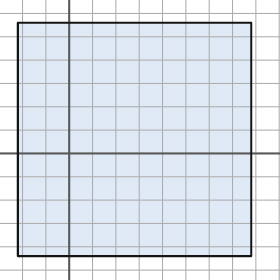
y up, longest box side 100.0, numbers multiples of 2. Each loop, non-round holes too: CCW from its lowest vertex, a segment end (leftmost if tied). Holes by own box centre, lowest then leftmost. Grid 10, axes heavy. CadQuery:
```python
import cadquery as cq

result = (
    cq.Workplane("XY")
    .moveTo(-22.0, -44.0)
    .lineTo(78.0, -44.0)
    .lineTo(78.0, 56.0)
    .lineTo(-22.0, 56.0)
    .close()
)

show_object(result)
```